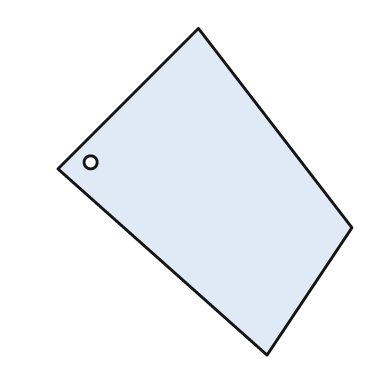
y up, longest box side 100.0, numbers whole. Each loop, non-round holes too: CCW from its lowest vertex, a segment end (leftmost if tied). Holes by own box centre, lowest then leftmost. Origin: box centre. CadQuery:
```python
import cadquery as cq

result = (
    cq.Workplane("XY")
    .moveTo(19.0, -50.0)
    .lineTo(45.0, -11.0)
    .lineTo(-2.0, 50.0)
    .lineTo(-45.0, 7.0)
    .close()
    .moveTo(-35.0, 9.0)
    .circle(2.0)
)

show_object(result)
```